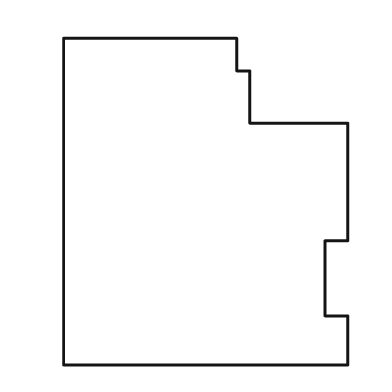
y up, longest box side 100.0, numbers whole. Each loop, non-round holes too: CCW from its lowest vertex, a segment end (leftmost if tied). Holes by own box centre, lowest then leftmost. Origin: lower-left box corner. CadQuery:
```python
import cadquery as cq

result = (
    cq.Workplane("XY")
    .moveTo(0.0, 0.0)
    .lineTo(87.0, 0.0)
    .lineTo(87.0, 15.0)
    .lineTo(80.0, 15.0)
    .lineTo(80.0, 38.0)
    .lineTo(87.0, 38.0)
    .lineTo(87.0, 74.0)
    .lineTo(57.0, 74.0)
    .lineTo(57.0, 90.0)
    .lineTo(53.0, 90.0)
    .lineTo(53.0, 100.0)
    .lineTo(0.0, 100.0)
    .close()
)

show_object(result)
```